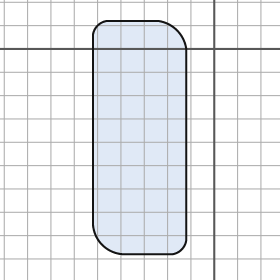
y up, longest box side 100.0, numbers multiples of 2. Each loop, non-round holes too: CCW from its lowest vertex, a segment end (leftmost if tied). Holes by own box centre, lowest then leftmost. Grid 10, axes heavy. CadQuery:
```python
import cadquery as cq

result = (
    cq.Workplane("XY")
    .moveTo(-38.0, -88.0)
    .lineTo(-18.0, -88.0)
    .threePointArc((-14.0, -86.0), (-12.0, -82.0))
    .lineTo(-12.0, 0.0)
    .threePointArc((-16.0, 8.0), (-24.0, 12.0))
    .lineTo(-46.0, 12.0)
    .threePointArc((-50.0, 10.0), (-52.0, 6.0))
    .lineTo(-52.0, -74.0)
    .threePointArc((-48.0, -84.0), (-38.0, -88.0))
    .close()
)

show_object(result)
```